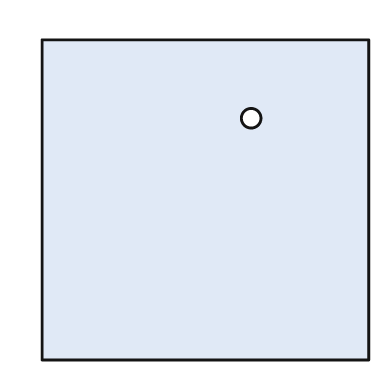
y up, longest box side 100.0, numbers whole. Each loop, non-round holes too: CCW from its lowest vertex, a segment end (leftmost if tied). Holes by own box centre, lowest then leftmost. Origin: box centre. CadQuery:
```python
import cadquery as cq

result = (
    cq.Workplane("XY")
    .moveTo(-50.0, -49.0)
    .lineTo(50.0, -49.0)
    .lineTo(50.0, 49.0)
    .lineTo(-50.0, 49.0)
    .close()
    .moveTo(14.0, 25.0)
    .circle(3.0)
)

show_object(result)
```